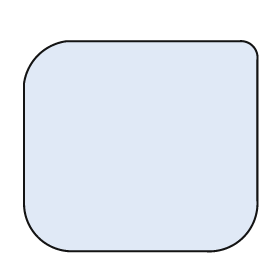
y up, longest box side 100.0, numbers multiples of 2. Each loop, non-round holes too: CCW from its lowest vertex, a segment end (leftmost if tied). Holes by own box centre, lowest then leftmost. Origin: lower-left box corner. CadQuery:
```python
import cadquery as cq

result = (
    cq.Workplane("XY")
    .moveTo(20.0, 0.0)
    .lineTo(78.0, 0.0)
    .threePointArc((94.0, 6.0), (100.0, 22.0))
    .lineTo(100.0, 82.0)
    .threePointArc((98.0, 88.0), (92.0, 90.0))
    .lineTo(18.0, 90.0)
    .threePointArc((6.0, 84.0), (0.0, 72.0))
    .lineTo(0.0, 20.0)
    .threePointArc((6.0, 6.0), (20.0, 0.0))
    .close()
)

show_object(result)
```